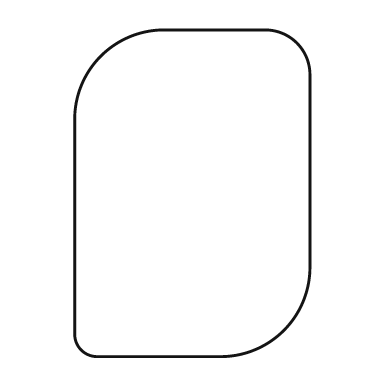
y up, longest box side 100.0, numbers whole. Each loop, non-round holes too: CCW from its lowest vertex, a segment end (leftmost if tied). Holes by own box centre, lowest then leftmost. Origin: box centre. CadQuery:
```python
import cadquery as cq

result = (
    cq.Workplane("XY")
    .moveTo(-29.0, -50.0)
    .lineTo(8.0, -50.0)
    .threePointArc((28.0, -42.0), (36.0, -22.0))
    .lineTo(36.0, 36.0)
    .threePointArc((32.0, 46.0), (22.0, 50.0))
    .lineTo(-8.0, 50.0)
    .threePointArc((-28.0, 42.0), (-36.0, 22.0))
    .lineTo(-36.0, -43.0)
    .threePointArc((-34.0, -48.0), (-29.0, -50.0))
    .close()
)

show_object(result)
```